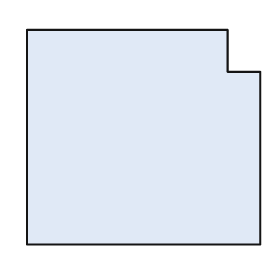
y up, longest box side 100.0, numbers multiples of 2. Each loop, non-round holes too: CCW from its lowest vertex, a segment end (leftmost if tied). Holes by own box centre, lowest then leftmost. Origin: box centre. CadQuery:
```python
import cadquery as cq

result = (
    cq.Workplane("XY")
    .moveTo(-50.0, -46.0)
    .lineTo(50.0, -46.0)
    .lineTo(50.0, 28.0)
    .lineTo(36.0, 28.0)
    .lineTo(36.0, 46.0)
    .lineTo(-50.0, 46.0)
    .close()
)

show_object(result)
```